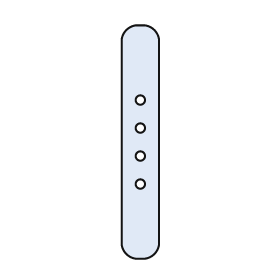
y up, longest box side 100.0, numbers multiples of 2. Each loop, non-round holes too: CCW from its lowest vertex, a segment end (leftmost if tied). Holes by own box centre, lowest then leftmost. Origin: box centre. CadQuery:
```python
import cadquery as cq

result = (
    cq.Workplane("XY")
    .moveTo(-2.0, -50.0)
    .lineTo(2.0, -50.0)
    .threePointArc((6.0, -48.0), (8.0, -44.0))
    .lineTo(8.0, 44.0)
    .threePointArc((6.0, 48.0), (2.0, 50.0))
    .lineTo(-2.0, 50.0)
    .threePointArc((-6.0, 48.0), (-8.0, 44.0))
    .lineTo(-8.0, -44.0)
    .threePointArc((-6.0, -48.0), (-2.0, -50.0))
    .close()
    .moveTo(0.0, -18.0)
    .circle(2.0)
    .moveTo(0.0, -6.0)
    .circle(2.0)
    .moveTo(0.0, 6.0)
    .circle(2.0)
    .moveTo(0.0, 18.0)
    .circle(2.0)
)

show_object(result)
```